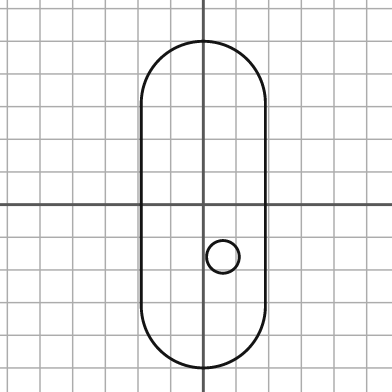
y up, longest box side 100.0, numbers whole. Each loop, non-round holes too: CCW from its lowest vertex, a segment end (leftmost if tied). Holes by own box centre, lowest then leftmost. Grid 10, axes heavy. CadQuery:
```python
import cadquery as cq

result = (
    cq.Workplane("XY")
    .moveTo(-19.0, -31.0)
    .threePointArc((0.0, -50.0), (19.0, -31.0))
    .lineTo(19.0, 31.0)
    .threePointArc((0.0, 50.0), (-19.0, 31.0))
    .close()
    .moveTo(6.0, -16.0)
    .circle(5.0)
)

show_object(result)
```